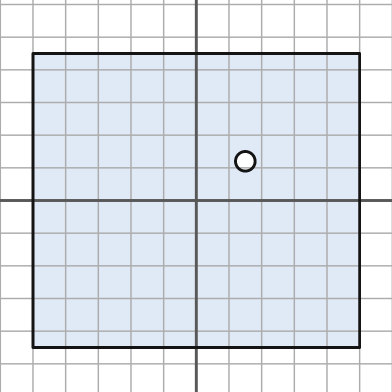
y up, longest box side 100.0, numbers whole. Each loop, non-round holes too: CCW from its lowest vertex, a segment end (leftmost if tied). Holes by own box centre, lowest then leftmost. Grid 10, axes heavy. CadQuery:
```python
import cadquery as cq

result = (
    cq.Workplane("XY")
    .moveTo(-50.0, -45.0)
    .lineTo(50.0, -45.0)
    .lineTo(50.0, 45.0)
    .lineTo(-50.0, 45.0)
    .close()
    .moveTo(15.0, 12.0)
    .circle(3.0)
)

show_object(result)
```